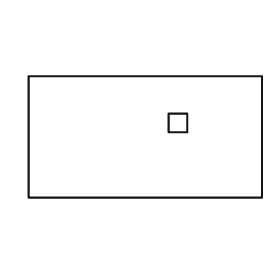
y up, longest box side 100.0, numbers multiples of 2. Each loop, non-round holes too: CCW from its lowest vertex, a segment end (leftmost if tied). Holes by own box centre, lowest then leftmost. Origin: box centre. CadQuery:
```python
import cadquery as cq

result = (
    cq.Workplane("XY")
    .moveTo(-50.0, -26.0)
    .lineTo(50.0, -26.0)
    .lineTo(50.0, 26.0)
    .lineTo(-50.0, 26.0)
    .close()
    .moveTo(10.0, 2.0)
    .lineTo(18.0, 2.0)
    .lineTo(18.0, 10.0)
    .lineTo(10.0, 10.0)
    .close()
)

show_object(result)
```